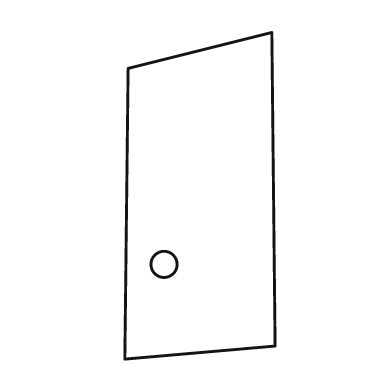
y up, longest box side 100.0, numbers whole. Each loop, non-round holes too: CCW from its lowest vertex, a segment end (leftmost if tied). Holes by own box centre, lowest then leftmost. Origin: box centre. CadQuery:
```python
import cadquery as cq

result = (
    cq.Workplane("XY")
    .moveTo(-23.0, -50.0)
    .lineTo(23.0, -46.0)
    .lineTo(22.0, 50.0)
    .lineTo(-22.0, 39.0)
    .close()
    .moveTo(-11.0, -21.0)
    .circle(4.0)
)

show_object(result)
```